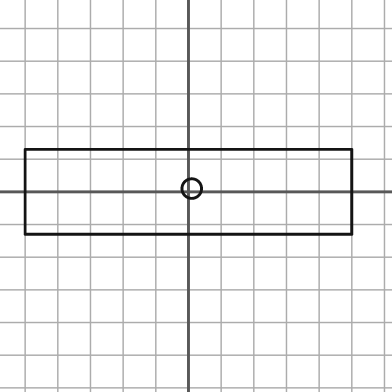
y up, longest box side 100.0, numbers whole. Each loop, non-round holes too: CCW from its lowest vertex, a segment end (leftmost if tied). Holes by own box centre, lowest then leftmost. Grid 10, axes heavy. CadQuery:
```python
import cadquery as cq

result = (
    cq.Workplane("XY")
    .moveTo(-50.0, -13.0)
    .lineTo(50.0, -13.0)
    .lineTo(50.0, 13.0)
    .lineTo(-50.0, 13.0)
    .close()
    .moveTo(1.0, 1.0)
    .circle(3.0)
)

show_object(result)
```